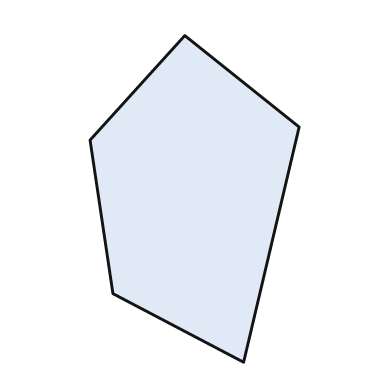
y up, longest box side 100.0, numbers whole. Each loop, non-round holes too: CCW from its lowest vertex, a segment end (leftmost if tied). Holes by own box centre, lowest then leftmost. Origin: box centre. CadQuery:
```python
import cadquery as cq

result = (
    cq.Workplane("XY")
    .moveTo(15.0, -50.0)
    .lineTo(32.0, 22.0)
    .lineTo(-3.0, 50.0)
    .lineTo(-32.0, 18.0)
    .lineTo(-25.0, -29.0)
    .close()
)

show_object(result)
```